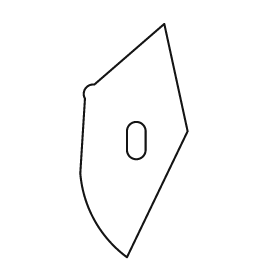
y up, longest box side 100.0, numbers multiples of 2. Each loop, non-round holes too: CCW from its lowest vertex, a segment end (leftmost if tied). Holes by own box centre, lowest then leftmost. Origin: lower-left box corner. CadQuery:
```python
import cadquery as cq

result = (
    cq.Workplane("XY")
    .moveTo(20.0, 0.0)
    .lineTo(46.0, 54.0)
    .lineTo(36.0, 100.0)
    .lineTo(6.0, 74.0)
    .threePointArc((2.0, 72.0), (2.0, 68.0))
    .lineTo(0.0, 36.0)
    .threePointArc((6.0, 16.0), (20.0, 0.0))
    .close()
    .moveTo(20.0, 46.0)
    .threePointArc((24.0, 42.0), (28.0, 46.0))
    .lineTo(28.0, 54.0)
    .threePointArc((24.0, 58.0), (20.0, 54.0))
    .close()
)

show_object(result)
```